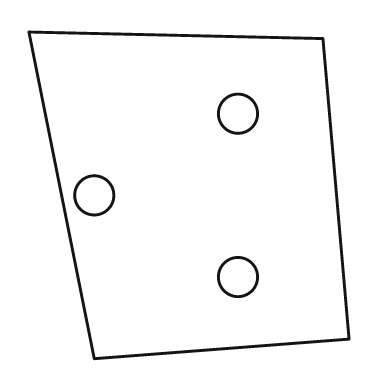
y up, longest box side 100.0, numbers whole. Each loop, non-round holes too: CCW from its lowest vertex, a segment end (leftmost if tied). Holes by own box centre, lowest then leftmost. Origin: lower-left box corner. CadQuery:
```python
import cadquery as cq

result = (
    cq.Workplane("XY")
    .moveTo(20.0, 0.0)
    .lineTo(98.0, 6.0)
    .lineTo(90.0, 98.0)
    .lineTo(0.0, 100.0)
    .close()
    .moveTo(64.0, 25.0)
    .circle(6.0)
    .moveTo(20.0, 50.0)
    .circle(6.0)
    .moveTo(64.0, 75.0)
    .circle(6.0)
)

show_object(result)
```